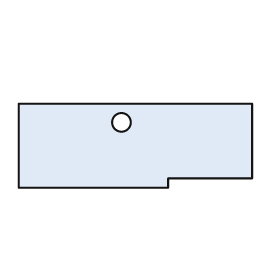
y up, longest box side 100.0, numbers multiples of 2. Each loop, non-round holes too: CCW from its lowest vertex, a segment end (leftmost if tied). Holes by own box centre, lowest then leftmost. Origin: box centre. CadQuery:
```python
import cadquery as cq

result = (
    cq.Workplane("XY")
    .moveTo(-50.0, -18.0)
    .lineTo(14.0, -18.0)
    .lineTo(14.0, -14.0)
    .lineTo(50.0, -14.0)
    .lineTo(50.0, 18.0)
    .lineTo(-50.0, 18.0)
    .close()
    .moveTo(-6.0, 10.0)
    .circle(4.0)
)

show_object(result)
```